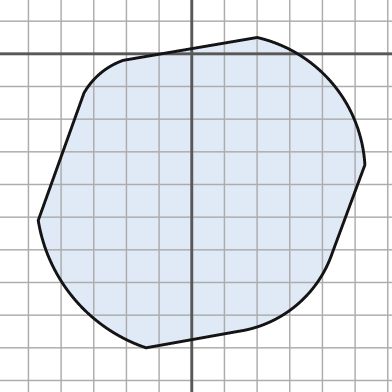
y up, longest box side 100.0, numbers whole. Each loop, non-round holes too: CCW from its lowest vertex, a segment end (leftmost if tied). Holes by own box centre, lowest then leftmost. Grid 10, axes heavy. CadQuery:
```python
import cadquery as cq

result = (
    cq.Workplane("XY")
    .moveTo(-14.0, -90.0)
    .lineTo(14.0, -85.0)
    .threePointArc((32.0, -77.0), (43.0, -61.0))
    .lineTo(53.0, -34.0)
    .threePointArc((43.0, -9.0), (20.0, 5.0))
    .lineTo(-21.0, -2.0)
    .threePointArc((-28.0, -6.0), (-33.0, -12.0))
    .lineTo(-47.0, -51.0)
    .threePointArc((-36.0, -75.0), (-14.0, -90.0))
    .close()
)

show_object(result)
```